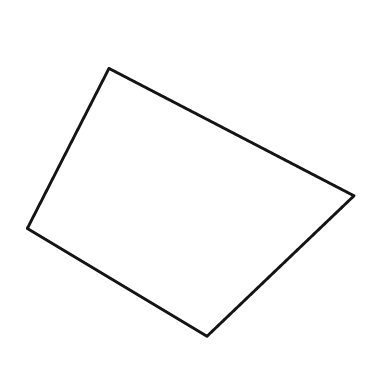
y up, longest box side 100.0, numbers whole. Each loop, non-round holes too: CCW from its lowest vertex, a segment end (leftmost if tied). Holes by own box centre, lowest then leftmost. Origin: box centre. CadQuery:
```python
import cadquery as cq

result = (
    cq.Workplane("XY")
    .moveTo(5.0, -41.0)
    .lineTo(50.0, 2.0)
    .lineTo(-25.0, 41.0)
    .lineTo(-50.0, -8.0)
    .close()
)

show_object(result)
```